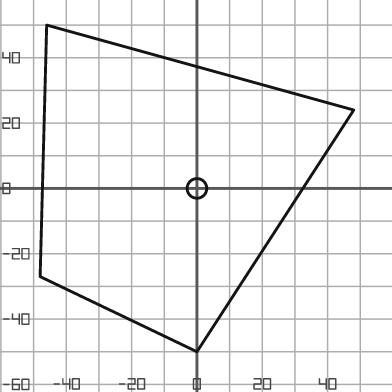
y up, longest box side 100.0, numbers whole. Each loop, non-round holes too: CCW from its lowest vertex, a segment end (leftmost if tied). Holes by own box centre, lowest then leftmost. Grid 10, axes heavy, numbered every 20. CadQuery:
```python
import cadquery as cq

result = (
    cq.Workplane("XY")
    .moveTo(0.0, -50.0)
    .lineTo(48.0, 24.0)
    .lineTo(-46.0, 50.0)
    .lineTo(-48.0, -27.0)
    .close()
    .moveTo(0.0, 0.0)
    .circle(3.0)
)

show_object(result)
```